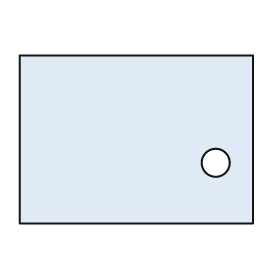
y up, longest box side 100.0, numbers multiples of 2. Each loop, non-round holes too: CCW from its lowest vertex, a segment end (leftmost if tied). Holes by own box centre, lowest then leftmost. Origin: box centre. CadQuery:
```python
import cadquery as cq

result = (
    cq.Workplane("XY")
    .moveTo(-50.0, -36.0)
    .lineTo(50.0, -36.0)
    .lineTo(50.0, 36.0)
    .lineTo(-50.0, 36.0)
    .close()
    .moveTo(34.0, -10.0)
    .circle(6.0)
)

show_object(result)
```